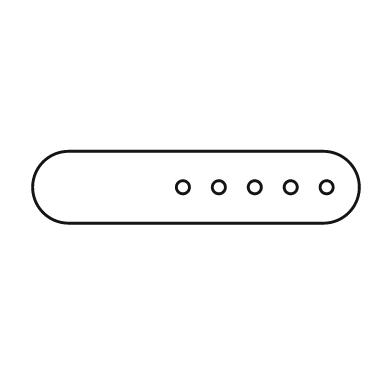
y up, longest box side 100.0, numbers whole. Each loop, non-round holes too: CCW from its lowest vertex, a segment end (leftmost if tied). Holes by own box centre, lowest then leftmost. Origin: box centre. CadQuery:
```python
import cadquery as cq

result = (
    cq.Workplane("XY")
    .moveTo(-39.0, -11.0)
    .lineTo(39.0, -11.0)
    .threePointArc((50.0, 0.0), (39.0, 11.0))
    .lineTo(-39.0, 11.0)
    .threePointArc((-50.0, 0.0), (-39.0, -11.0))
    .close()
    .moveTo(-4.0, 0.0)
    .circle(2.0)
    .moveTo(7.0, 0.0)
    .circle(2.0)
    .moveTo(18.0, 0.0)
    .circle(2.0)
    .moveTo(29.0, 0.0)
    .circle(2.0)
    .moveTo(40.0, 0.0)
    .circle(2.0)
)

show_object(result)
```